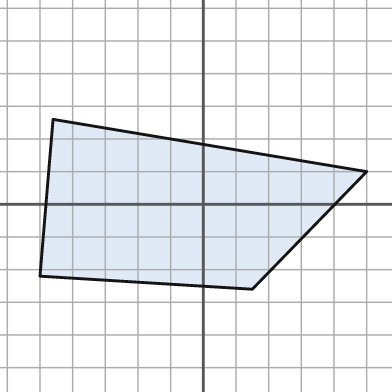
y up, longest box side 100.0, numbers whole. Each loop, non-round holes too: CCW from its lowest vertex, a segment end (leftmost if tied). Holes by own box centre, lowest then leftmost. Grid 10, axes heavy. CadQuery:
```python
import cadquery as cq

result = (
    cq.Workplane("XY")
    .moveTo(15.0, -26.0)
    .lineTo(50.0, 10.0)
    .lineTo(-46.0, 26.0)
    .lineTo(-50.0, -22.0)
    .close()
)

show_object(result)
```